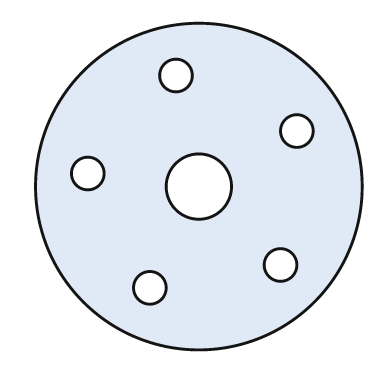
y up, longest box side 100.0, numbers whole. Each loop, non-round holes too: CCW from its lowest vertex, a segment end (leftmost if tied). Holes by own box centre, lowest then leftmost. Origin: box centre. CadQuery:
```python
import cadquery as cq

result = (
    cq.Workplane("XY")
    .moveTo(0.0, 0.0)
    .circle(50.0)
    .moveTo(-15.0, -31.0)
    .circle(5.0)
    .moveTo(25.0, -24.0)
    .circle(5.0)
    .moveTo(0.0, 0.0)
    .circle(10.0)
    .moveTo(-34.0, 4.0)
    .circle(5.0)
    .moveTo(30.0, 17.0)
    .circle(5.0)
    .moveTo(-7.0, 34.0)
    .circle(5.0)
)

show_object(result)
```